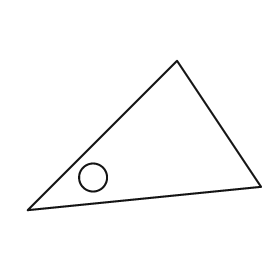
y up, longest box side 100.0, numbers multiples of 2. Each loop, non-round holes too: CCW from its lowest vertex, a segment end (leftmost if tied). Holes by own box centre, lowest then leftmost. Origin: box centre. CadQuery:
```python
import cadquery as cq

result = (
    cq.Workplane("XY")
    .moveTo(-50.0, -32.0)
    .lineTo(50.0, -22.0)
    .lineTo(14.0, 32.0)
    .close()
    .moveTo(-22.0, -18.0)
    .circle(6.0)
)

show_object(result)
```